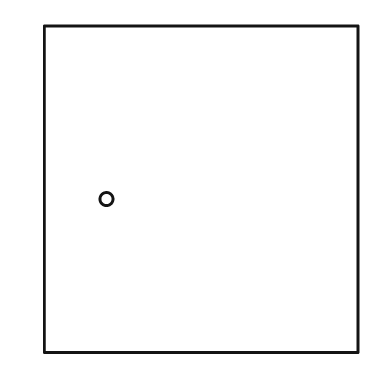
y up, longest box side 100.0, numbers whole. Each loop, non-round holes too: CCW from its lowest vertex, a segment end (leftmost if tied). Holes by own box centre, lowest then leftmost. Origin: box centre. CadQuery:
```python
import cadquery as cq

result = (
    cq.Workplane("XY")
    .moveTo(-48.0, -50.0)
    .lineTo(48.0, -50.0)
    .lineTo(48.0, 50.0)
    .lineTo(-48.0, 50.0)
    .close()
    .moveTo(-29.0, -3.0)
    .circle(2.0)
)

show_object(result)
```